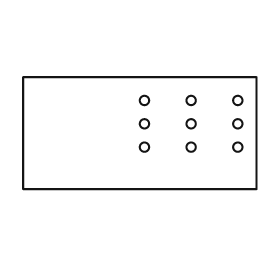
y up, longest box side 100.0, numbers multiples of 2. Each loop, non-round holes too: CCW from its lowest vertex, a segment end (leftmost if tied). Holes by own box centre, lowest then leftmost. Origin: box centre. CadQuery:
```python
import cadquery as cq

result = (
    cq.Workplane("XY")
    .moveTo(-50.0, -24.0)
    .lineTo(50.0, -24.0)
    .lineTo(50.0, 24.0)
    .lineTo(-50.0, 24.0)
    .close()
    .moveTo(2.0, -6.0)
    .circle(2.0)
    .moveTo(22.0, -6.0)
    .circle(2.0)
    .moveTo(42.0, -6.0)
    .circle(2.0)
    .moveTo(2.0, 4.0)
    .circle(2.0)
    .moveTo(22.0, 4.0)
    .circle(2.0)
    .moveTo(42.0, 4.0)
    .circle(2.0)
    .moveTo(2.0, 14.0)
    .circle(2.0)
    .moveTo(22.0, 14.0)
    .circle(2.0)
    .moveTo(42.0, 14.0)
    .circle(2.0)
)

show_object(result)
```